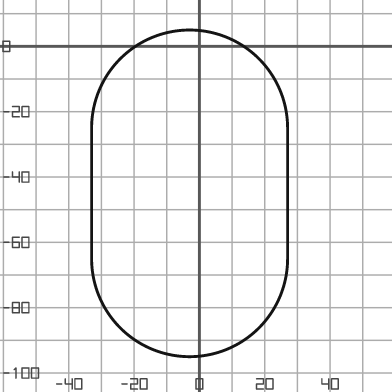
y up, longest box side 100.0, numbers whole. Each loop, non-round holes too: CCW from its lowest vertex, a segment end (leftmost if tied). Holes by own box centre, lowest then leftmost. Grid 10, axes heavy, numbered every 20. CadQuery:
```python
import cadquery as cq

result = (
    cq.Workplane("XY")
    .moveTo(-33.0, -65.0)
    .threePointArc((-3.0, -95.0), (27.0, -65.0))
    .lineTo(27.0, -25.0)
    .threePointArc((-3.0, 5.0), (-33.0, -25.0))
    .close()
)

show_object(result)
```